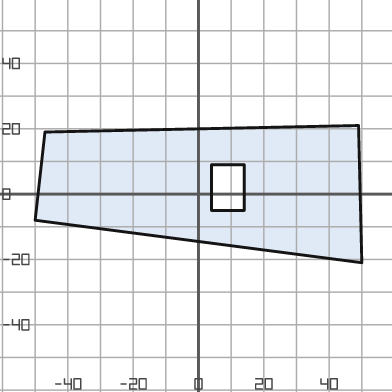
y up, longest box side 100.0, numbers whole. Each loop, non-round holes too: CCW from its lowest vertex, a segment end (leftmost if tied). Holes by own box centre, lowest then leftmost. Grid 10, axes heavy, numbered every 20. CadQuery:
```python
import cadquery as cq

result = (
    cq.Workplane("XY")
    .moveTo(50.0, -21.0)
    .lineTo(49.0, 21.0)
    .lineTo(-47.0, 19.0)
    .lineTo(-50.0, -8.0)
    .close()
    .moveTo(4.0, -5.0)
    .lineTo(14.0, -5.0)
    .lineTo(14.0, 9.0)
    .lineTo(4.0, 9.0)
    .close()
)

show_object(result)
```